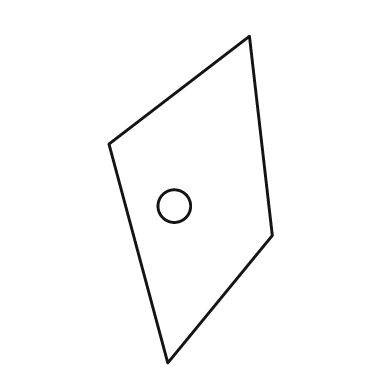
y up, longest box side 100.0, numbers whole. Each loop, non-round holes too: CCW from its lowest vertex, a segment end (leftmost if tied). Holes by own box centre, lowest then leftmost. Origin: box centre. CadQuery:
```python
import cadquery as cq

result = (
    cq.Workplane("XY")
    .moveTo(-7.0, -50.0)
    .lineTo(25.0, -11.0)
    .lineTo(18.0, 50.0)
    .lineTo(-25.0, 17.0)
    .close()
    .moveTo(-5.0, -2.0)
    .circle(5.0)
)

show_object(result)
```